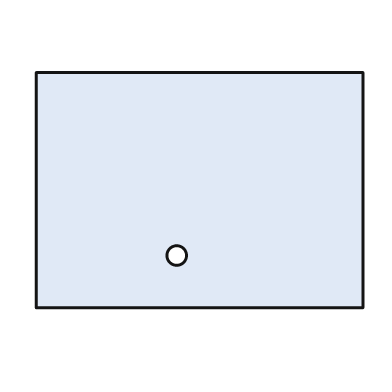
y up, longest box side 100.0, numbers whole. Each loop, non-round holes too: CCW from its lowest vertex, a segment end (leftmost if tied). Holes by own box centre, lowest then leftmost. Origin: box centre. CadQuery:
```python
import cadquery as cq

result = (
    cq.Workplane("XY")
    .moveTo(-50.0, -36.0)
    .lineTo(50.0, -36.0)
    .lineTo(50.0, 36.0)
    .lineTo(-50.0, 36.0)
    .close()
    .moveTo(-7.0, -20.0)
    .circle(3.0)
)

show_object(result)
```